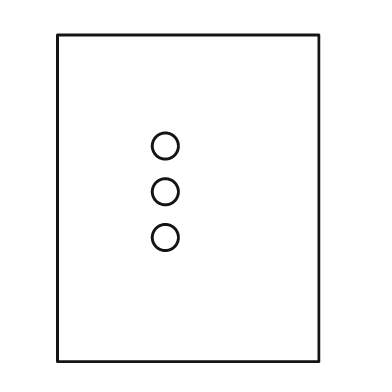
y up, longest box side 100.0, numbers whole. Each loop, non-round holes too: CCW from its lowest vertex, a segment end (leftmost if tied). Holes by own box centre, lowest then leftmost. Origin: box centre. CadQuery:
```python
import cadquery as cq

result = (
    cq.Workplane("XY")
    .moveTo(-40.0, -50.0)
    .lineTo(40.0, -50.0)
    .lineTo(40.0, 50.0)
    .lineTo(-40.0, 50.0)
    .close()
    .moveTo(-7.0, -12.0)
    .circle(4.0)
    .moveTo(-7.0, 2.0)
    .circle(4.0)
    .moveTo(-7.0, 16.0)
    .circle(4.0)
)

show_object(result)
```